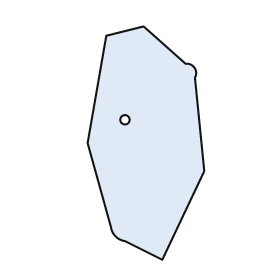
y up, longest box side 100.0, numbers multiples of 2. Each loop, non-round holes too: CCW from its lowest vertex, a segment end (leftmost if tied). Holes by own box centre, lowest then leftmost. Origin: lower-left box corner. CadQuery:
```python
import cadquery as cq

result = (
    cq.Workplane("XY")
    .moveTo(32.0, 0.0)
    .lineTo(50.0, 38.0)
    .lineTo(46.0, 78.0)
    .threePointArc((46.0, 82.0), (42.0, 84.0))
    .lineTo(24.0, 100.0)
    .lineTo(8.0, 96.0)
    .lineTo(0.0, 50.0)
    .lineTo(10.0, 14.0)
    .threePointArc((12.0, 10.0), (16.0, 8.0))
    .close()
    .moveTo(16.0, 60.0)
    .circle(2.0)
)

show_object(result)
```